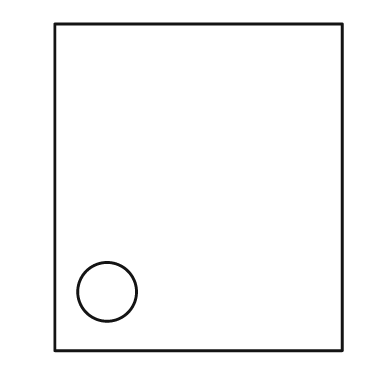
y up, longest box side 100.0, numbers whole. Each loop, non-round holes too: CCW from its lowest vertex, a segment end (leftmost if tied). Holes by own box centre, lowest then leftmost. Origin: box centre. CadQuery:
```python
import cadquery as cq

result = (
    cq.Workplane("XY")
    .moveTo(-44.0, -50.0)
    .lineTo(44.0, -50.0)
    .lineTo(44.0, 50.0)
    .lineTo(-44.0, 50.0)
    .close()
    .moveTo(-28.0, -32.0)
    .circle(9.0)
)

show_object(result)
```